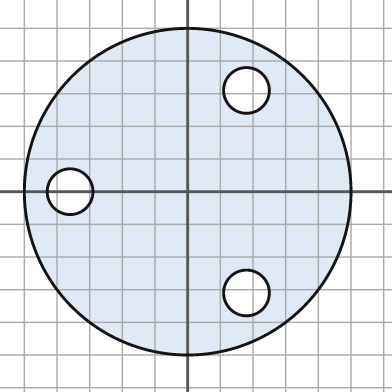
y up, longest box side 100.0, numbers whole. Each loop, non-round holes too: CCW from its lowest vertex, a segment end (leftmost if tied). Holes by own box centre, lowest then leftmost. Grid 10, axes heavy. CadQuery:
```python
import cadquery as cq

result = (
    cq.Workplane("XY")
    .moveTo(0.0, 0.0)
    .circle(50.0)
    .moveTo(18.0, -31.0)
    .circle(7.0)
    .moveTo(-36.0, 0.0)
    .circle(7.0)
    .moveTo(18.0, 31.0)
    .circle(7.0)
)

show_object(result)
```